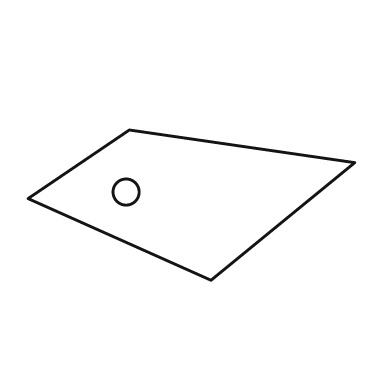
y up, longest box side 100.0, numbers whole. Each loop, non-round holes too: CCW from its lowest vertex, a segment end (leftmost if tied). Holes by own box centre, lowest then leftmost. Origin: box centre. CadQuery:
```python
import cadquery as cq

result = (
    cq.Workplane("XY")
    .moveTo(6.0, -23.0)
    .lineTo(50.0, 13.0)
    .lineTo(-19.0, 23.0)
    .lineTo(-50.0, 2.0)
    .close()
    .moveTo(-20.0, 4.0)
    .circle(4.0)
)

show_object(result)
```